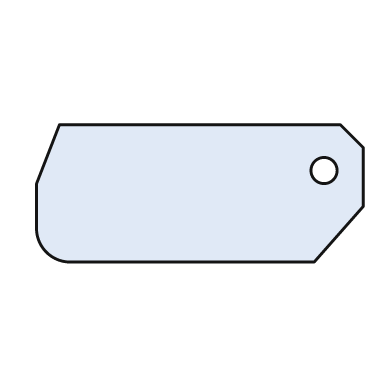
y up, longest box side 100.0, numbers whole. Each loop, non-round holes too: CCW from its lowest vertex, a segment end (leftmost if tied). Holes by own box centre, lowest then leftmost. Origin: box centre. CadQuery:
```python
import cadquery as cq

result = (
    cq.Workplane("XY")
    .moveTo(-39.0, -21.0)
    .lineTo(35.0, -21.0)
    .lineTo(50.0, -4.0)
    .lineTo(50.0, 14.0)
    .lineTo(43.0, 21.0)
    .lineTo(-43.0, 21.0)
    .lineTo(-50.0, 3.0)
    .lineTo(-50.0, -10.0)
    .threePointArc((-47.0, -18.0), (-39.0, -21.0))
    .close()
    .moveTo(38.0, 7.0)
    .circle(4.0)
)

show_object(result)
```